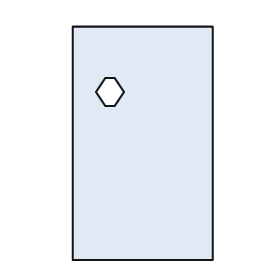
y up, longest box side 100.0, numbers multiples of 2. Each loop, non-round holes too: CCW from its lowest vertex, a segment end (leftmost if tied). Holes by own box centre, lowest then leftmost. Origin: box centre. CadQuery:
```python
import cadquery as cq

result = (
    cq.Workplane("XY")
    .moveTo(-30.0, -50.0)
    .lineTo(30.0, -50.0)
    .lineTo(30.0, 50.0)
    .lineTo(-30.0, 50.0)
    .close()
    .moveTo(-16.0, 16.0)
    .lineTo(-12.0, 16.0)
    .lineTo(-8.0, 22.0)
    .lineTo(-12.0, 28.0)
    .lineTo(-16.0, 28.0)
    .lineTo(-20.0, 22.0)
    .close()
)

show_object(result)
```